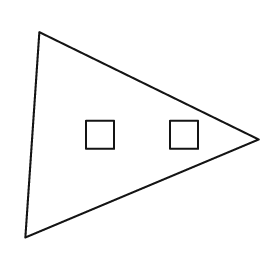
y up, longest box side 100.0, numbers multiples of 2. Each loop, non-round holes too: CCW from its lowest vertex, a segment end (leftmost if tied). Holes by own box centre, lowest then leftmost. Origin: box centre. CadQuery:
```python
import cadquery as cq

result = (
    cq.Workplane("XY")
    .moveTo(-50.0, -44.0)
    .lineTo(50.0, -2.0)
    .lineTo(-44.0, 44.0)
    .close()
    .moveTo(-24.0, -6.0)
    .lineTo(-12.0, -6.0)
    .lineTo(-12.0, 6.0)
    .lineTo(-24.0, 6.0)
    .close()
    .moveTo(12.0, -6.0)
    .lineTo(24.0, -6.0)
    .lineTo(24.0, 6.0)
    .lineTo(12.0, 6.0)
    .close()
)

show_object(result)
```